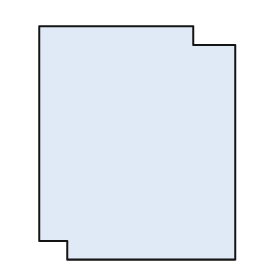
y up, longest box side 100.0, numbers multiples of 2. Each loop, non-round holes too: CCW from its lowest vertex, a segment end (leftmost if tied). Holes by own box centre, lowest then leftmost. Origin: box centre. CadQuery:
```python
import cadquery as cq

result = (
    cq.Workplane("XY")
    .moveTo(-30.0, -50.0)
    .lineTo(42.0, -50.0)
    .lineTo(42.0, 42.0)
    .lineTo(24.0, 42.0)
    .lineTo(24.0, 50.0)
    .lineTo(-42.0, 50.0)
    .lineTo(-42.0, -42.0)
    .lineTo(-30.0, -42.0)
    .close()
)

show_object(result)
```